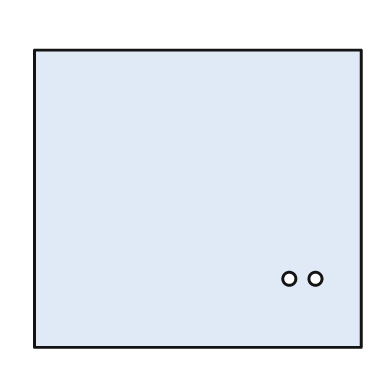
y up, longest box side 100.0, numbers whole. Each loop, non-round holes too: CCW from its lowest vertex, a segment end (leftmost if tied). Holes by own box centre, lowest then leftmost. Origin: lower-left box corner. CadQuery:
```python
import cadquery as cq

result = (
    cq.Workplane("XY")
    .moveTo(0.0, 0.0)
    .lineTo(100.0, 0.0)
    .lineTo(100.0, 91.0)
    .lineTo(0.0, 91.0)
    .close()
    .moveTo(78.0, 21.0)
    .circle(2.0)
    .moveTo(86.0, 21.0)
    .circle(2.0)
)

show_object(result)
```